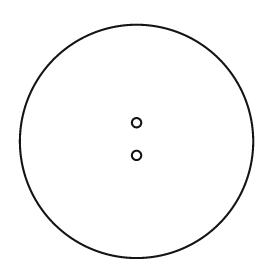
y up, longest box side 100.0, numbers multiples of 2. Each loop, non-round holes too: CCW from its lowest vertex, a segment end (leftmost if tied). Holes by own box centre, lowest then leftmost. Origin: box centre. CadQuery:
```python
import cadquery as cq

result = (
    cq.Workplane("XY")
    .moveTo(0.0, 0.0)
    .circle(50.0)
    .moveTo(0.0, -6.0)
    .circle(2.0)
    .moveTo(0.0, 8.0)
    .circle(2.0)
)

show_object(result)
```